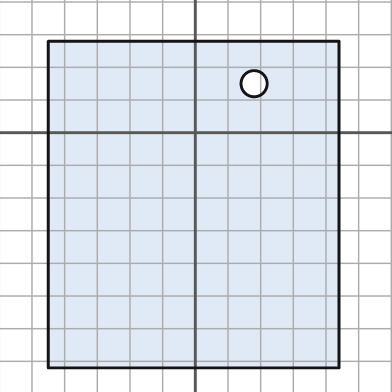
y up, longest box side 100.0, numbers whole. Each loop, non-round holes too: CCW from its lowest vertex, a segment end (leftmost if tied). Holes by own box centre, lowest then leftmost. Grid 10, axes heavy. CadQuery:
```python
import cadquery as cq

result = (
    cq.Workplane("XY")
    .moveTo(-45.0, -72.0)
    .lineTo(44.0, -72.0)
    .lineTo(44.0, 28.0)
    .lineTo(-45.0, 28.0)
    .close()
    .moveTo(18.0, 15.0)
    .circle(4.0)
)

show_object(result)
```